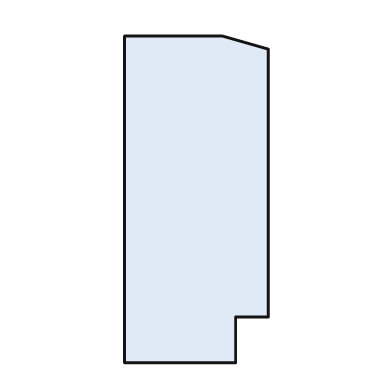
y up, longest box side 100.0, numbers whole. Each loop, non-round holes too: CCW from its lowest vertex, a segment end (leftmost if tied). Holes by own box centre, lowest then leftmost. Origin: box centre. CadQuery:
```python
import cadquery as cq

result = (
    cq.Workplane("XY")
    .moveTo(-22.0, -50.0)
    .lineTo(12.0, -50.0)
    .lineTo(12.0, -36.0)
    .lineTo(22.0, -36.0)
    .lineTo(22.0, 46.0)
    .lineTo(8.0, 50.0)
    .lineTo(-22.0, 50.0)
    .close()
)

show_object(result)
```